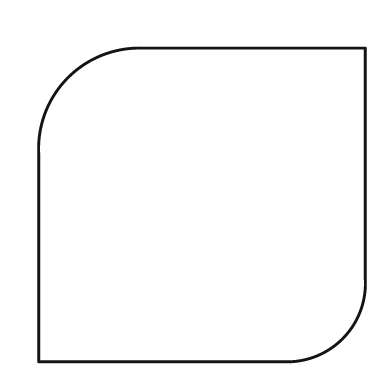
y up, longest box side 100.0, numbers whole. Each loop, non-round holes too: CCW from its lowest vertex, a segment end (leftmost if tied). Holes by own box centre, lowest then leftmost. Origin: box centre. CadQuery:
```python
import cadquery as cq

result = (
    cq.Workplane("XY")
    .moveTo(-50.0, -48.0)
    .lineTo(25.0, -48.0)
    .threePointArc((43.0, -41.0), (50.0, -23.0))
    .lineTo(50.0, 48.0)
    .lineTo(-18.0, 48.0)
    .threePointArc((-41.0, 39.0), (-50.0, 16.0))
    .close()
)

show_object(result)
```